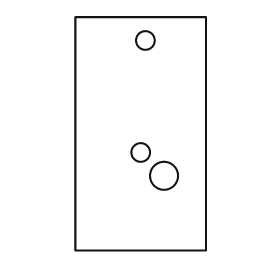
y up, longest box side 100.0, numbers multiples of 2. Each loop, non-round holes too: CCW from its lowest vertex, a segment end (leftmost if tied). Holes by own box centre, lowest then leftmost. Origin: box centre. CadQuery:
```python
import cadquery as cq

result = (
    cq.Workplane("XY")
    .moveTo(-28.0, -50.0)
    .lineTo(28.0, -50.0)
    .lineTo(28.0, 50.0)
    .lineTo(-28.0, 50.0)
    .close()
    .moveTo(10.0, -18.0)
    .circle(6.0)
    .moveTo(0.0, -8.0)
    .circle(4.0)
    .moveTo(2.0, 40.0)
    .circle(4.0)
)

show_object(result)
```